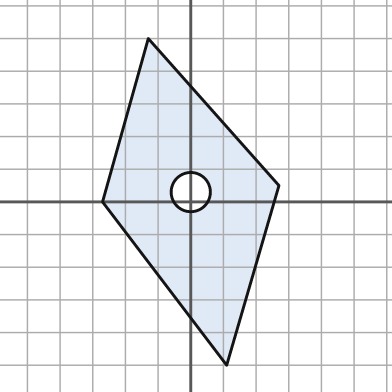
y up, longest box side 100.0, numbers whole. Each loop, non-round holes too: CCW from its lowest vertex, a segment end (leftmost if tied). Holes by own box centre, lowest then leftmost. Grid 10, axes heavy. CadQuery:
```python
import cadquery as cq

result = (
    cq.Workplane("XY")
    .moveTo(11.0, -50.0)
    .lineTo(27.0, 5.0)
    .lineTo(-13.0, 50.0)
    .lineTo(-27.0, 0.0)
    .close()
    .moveTo(0.0, 3.0)
    .circle(6.0)
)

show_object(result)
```